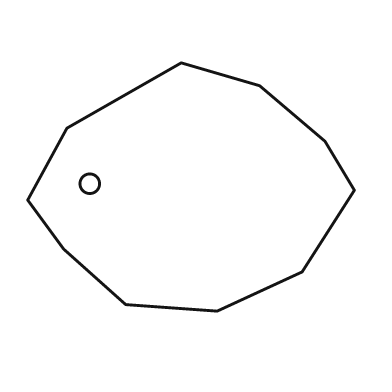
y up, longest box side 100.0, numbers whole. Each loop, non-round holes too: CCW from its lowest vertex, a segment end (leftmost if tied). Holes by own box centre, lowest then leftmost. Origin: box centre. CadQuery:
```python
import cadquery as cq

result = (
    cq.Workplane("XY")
    .moveTo(8.0, -38.0)
    .lineTo(34.0, -26.0)
    .lineTo(50.0, -1.0)
    .lineTo(41.0, 14.0)
    .lineTo(21.0, 31.0)
    .lineTo(-3.0, 38.0)
    .lineTo(-38.0, 18.0)
    .lineTo(-50.0, -4.0)
    .lineTo(-39.0, -19.0)
    .lineTo(-20.0, -36.0)
    .close()
    .moveTo(-31.0, 1.0)
    .circle(3.0)
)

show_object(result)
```